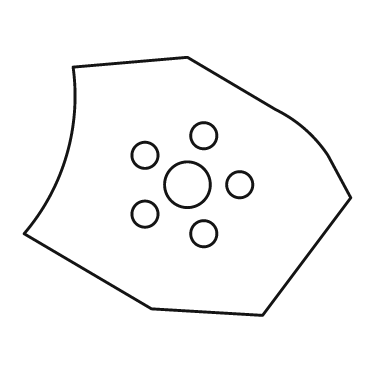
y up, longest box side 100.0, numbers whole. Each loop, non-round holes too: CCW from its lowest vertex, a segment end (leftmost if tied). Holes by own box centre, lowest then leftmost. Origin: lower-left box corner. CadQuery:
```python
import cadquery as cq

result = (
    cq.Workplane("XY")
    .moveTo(73.0, 0.0)
    .lineTo(100.0, 36.0)
    .lineTo(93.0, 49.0)
    .threePointArc((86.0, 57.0), (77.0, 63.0))
    .lineTo(50.0, 79.0)
    .lineTo(15.0, 76.0)
    .threePointArc((13.0, 49.0), (0.0, 25.0))
    .lineTo(39.0, 2.0)
    .close()
    .moveTo(55.0, 25.0)
    .circle(4.0)
    .moveTo(37.0, 31.0)
    .circle(4.0)
    .moveTo(50.0, 40.0)
    .circle(7.0)
    .moveTo(66.0, 40.0)
    .circle(4.0)
    .moveTo(37.0, 49.0)
    .circle(4.0)
    .moveTo(55.0, 55.0)
    .circle(4.0)
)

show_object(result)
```